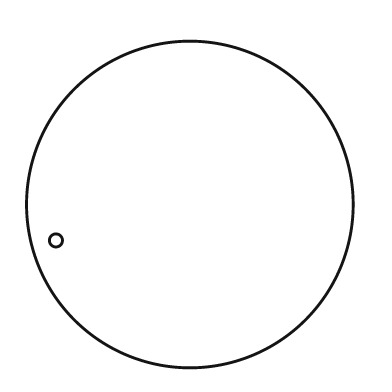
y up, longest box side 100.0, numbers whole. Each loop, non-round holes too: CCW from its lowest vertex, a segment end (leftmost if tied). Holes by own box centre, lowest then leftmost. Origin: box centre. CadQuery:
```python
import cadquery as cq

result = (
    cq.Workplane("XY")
    .moveTo(0.0, 0.0)
    .circle(50.0)
    .moveTo(-41.0, -11.0)
    .circle(2.0)
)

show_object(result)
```